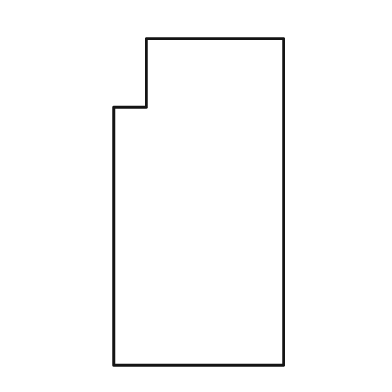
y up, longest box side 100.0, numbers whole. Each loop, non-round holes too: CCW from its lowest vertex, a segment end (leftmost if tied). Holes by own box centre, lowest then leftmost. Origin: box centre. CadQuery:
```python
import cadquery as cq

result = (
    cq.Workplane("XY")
    .moveTo(-26.0, -50.0)
    .lineTo(26.0, -50.0)
    .lineTo(26.0, 50.0)
    .lineTo(-16.0, 50.0)
    .lineTo(-16.0, 29.0)
    .lineTo(-26.0, 29.0)
    .close()
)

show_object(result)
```